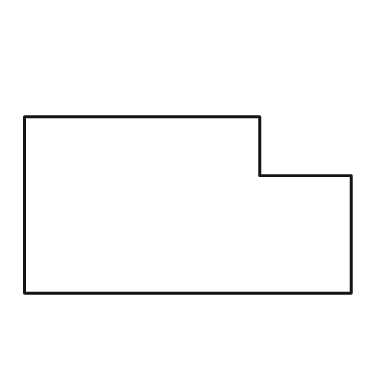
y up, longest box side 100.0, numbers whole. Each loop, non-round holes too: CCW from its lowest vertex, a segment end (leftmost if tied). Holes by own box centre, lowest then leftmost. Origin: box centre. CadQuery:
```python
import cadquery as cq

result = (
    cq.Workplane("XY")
    .moveTo(-50.0, -27.0)
    .lineTo(50.0, -27.0)
    .lineTo(50.0, 9.0)
    .lineTo(22.0, 9.0)
    .lineTo(22.0, 27.0)
    .lineTo(-50.0, 27.0)
    .close()
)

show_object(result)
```